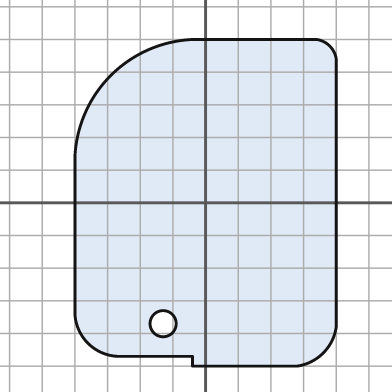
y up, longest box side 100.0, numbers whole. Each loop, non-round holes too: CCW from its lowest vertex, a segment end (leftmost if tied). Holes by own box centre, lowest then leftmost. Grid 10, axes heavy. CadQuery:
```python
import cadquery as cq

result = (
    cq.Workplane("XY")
    .moveTo(-4.0, -50.0)
    .lineTo(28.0, -50.0)
    .threePointArc((36.0, -46.0), (40.0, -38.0))
    .lineTo(40.0, 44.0)
    .threePointArc((38.0, 48.0), (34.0, 50.0))
    .lineTo(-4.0, 50.0)
    .threePointArc((-29.0, 39.0), (-40.0, 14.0))
    .lineTo(-40.0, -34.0)
    .threePointArc((-36.0, -43.0), (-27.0, -47.0))
    .lineTo(-4.0, -47.0)
    .close()
    .moveTo(-13.0, -37.0)
    .circle(4.0)
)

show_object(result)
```